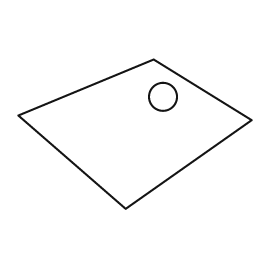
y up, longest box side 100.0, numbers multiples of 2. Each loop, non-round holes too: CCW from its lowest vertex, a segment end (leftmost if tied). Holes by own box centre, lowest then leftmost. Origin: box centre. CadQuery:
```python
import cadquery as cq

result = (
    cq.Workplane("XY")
    .moveTo(-4.0, -32.0)
    .lineTo(50.0, 6.0)
    .lineTo(8.0, 32.0)
    .lineTo(-50.0, 8.0)
    .close()
    .moveTo(12.0, 16.0)
    .circle(6.0)
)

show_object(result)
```